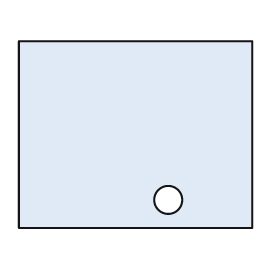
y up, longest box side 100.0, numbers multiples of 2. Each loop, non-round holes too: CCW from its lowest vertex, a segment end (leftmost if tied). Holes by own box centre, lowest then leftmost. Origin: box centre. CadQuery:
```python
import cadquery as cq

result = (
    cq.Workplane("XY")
    .moveTo(-50.0, -40.0)
    .lineTo(50.0, -40.0)
    .lineTo(50.0, 40.0)
    .lineTo(-50.0, 40.0)
    .close()
    .moveTo(14.0, -28.0)
    .circle(6.0)
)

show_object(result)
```